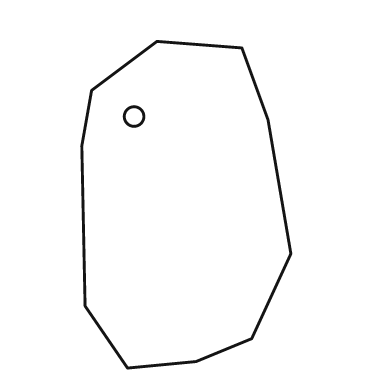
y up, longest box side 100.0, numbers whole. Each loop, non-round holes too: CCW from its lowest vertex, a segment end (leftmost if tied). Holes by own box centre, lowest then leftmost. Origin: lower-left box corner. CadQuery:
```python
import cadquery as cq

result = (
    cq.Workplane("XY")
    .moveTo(14.0, 0.0)
    .lineTo(35.0, 2.0)
    .lineTo(52.0, 9.0)
    .lineTo(64.0, 35.0)
    .lineTo(57.0, 76.0)
    .lineTo(49.0, 98.0)
    .lineTo(23.0, 100.0)
    .lineTo(3.0, 85.0)
    .lineTo(0.0, 68.0)
    .lineTo(1.0, 19.0)
    .close()
    .moveTo(16.0, 77.0)
    .circle(3.0)
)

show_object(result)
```